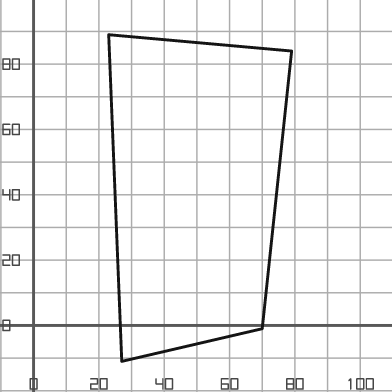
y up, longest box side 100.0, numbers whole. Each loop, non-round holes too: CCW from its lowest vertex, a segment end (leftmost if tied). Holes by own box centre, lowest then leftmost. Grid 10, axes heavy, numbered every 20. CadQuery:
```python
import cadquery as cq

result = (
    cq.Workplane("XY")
    .moveTo(27.0, -11.0)
    .lineTo(70.0, -1.0)
    .lineTo(79.0, 84.0)
    .lineTo(23.0, 89.0)
    .close()
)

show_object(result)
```